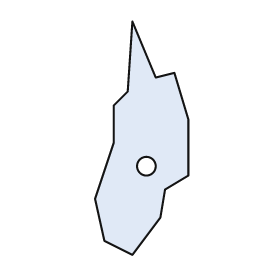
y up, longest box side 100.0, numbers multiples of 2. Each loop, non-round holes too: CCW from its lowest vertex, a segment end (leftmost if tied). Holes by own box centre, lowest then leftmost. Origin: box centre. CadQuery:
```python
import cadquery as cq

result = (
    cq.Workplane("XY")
    .moveTo(-4.0, -50.0)
    .lineTo(8.0, -34.0)
    .lineTo(10.0, -22.0)
    .lineTo(20.0, -16.0)
    .lineTo(20.0, 8.0)
    .lineTo(14.0, 28.0)
    .lineTo(6.0, 26.0)
    .lineTo(-4.0, 50.0)
    .lineTo(-6.0, 20.0)
    .lineTo(-12.0, 14.0)
    .lineTo(-12.0, -2.0)
    .lineTo(-20.0, -26.0)
    .lineTo(-16.0, -44.0)
    .close()
    .moveTo(2.0, -12.0)
    .circle(4.0)
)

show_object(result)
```